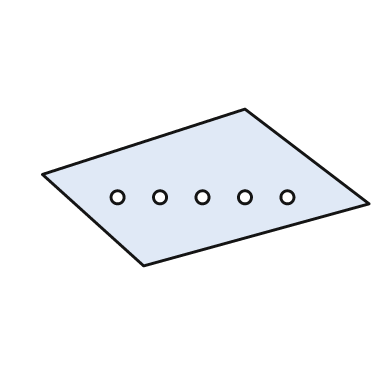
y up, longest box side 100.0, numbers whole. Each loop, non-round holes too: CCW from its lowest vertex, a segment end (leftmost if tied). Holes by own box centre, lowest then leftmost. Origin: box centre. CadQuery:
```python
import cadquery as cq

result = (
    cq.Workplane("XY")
    .moveTo(-19.0, -24.0)
    .lineTo(50.0, -5.0)
    .lineTo(12.0, 24.0)
    .lineTo(-50.0, 4.0)
    .close()
    .moveTo(-27.0, -3.0)
    .circle(2.0)
    .moveTo(-14.0, -3.0)
    .circle(2.0)
    .moveTo(-1.0, -3.0)
    .circle(2.0)
    .moveTo(12.0, -3.0)
    .circle(2.0)
    .moveTo(25.0, -3.0)
    .circle(2.0)
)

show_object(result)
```